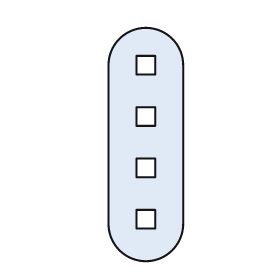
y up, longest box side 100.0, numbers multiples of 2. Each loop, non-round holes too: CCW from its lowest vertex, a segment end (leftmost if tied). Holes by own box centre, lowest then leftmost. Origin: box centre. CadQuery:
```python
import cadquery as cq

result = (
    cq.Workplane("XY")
    .moveTo(-16.0, -34.0)
    .threePointArc((0.0, -50.0), (16.0, -34.0))
    .lineTo(16.0, 34.0)
    .threePointArc((0.0, 50.0), (-16.0, 34.0))
    .close()
    .moveTo(-4.0, -36.0)
    .lineTo(4.0, -36.0)
    .lineTo(4.0, -28.0)
    .lineTo(-4.0, -28.0)
    .close()
    .moveTo(-4.0, -14.0)
    .lineTo(4.0, -14.0)
    .lineTo(4.0, -6.0)
    .lineTo(-4.0, -6.0)
    .close()
    .moveTo(-4.0, 8.0)
    .lineTo(4.0, 8.0)
    .lineTo(4.0, 16.0)
    .lineTo(-4.0, 16.0)
    .close()
    .moveTo(-4.0, 30.0)
    .lineTo(4.0, 30.0)
    .lineTo(4.0, 38.0)
    .lineTo(-4.0, 38.0)
    .close()
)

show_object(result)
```